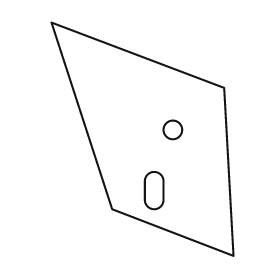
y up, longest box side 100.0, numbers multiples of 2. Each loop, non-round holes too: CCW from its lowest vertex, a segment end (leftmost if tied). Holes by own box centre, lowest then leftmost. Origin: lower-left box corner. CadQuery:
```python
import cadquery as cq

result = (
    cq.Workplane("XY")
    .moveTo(78.0, 0.0)
    .lineTo(74.0, 72.0)
    .lineTo(0.0, 100.0)
    .lineTo(26.0, 20.0)
    .close()
    .moveTo(40.0, 24.0)
    .threePointArc((44.0, 20.0), (48.0, 24.0))
    .lineTo(48.0, 32.0)
    .threePointArc((44.0, 36.0), (40.0, 32.0))
    .close()
    .moveTo(52.0, 54.0)
    .circle(4.0)
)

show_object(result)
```